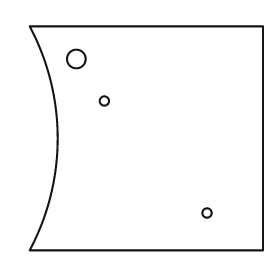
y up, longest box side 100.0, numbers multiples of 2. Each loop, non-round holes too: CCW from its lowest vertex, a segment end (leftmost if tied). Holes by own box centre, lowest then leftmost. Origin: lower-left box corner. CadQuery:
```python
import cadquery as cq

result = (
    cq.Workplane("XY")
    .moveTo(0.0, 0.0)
    .lineTo(100.0, 0.0)
    .lineTo(100.0, 96.0)
    .lineTo(0.0, 96.0)
    .threePointArc((12.0, 48.0), (0.0, 0.0))
    .close()
    .moveTo(76.0, 16.0)
    .circle(2.0)
    .moveTo(32.0, 64.0)
    .circle(2.0)
    .moveTo(20.0, 82.0)
    .circle(4.0)
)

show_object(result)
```